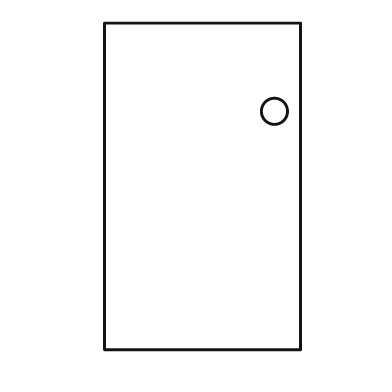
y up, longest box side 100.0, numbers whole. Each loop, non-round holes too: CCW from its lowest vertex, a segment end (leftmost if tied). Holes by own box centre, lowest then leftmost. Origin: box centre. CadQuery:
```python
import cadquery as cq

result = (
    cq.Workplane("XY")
    .moveTo(-30.0, -50.0)
    .lineTo(30.0, -50.0)
    .lineTo(30.0, 50.0)
    .lineTo(-30.0, 50.0)
    .close()
    .moveTo(22.0, 23.0)
    .circle(4.0)
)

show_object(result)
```